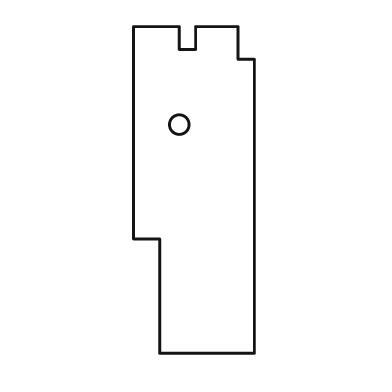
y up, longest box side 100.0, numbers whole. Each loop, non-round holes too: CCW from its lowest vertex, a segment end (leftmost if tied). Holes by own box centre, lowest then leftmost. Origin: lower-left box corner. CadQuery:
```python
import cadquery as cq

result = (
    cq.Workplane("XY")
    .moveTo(8.0, 0.0)
    .lineTo(37.0, 0.0)
    .lineTo(37.0, 90.0)
    .lineTo(32.0, 90.0)
    .lineTo(32.0, 100.0)
    .lineTo(19.0, 100.0)
    .lineTo(19.0, 93.0)
    .lineTo(14.0, 93.0)
    .lineTo(14.0, 100.0)
    .lineTo(0.0, 100.0)
    .lineTo(0.0, 35.0)
    .lineTo(8.0, 35.0)
    .close()
    .moveTo(14.0, 70.0)
    .circle(3.0)
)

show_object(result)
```